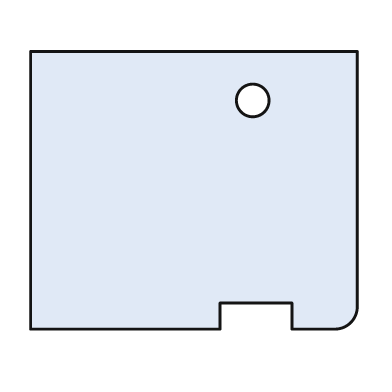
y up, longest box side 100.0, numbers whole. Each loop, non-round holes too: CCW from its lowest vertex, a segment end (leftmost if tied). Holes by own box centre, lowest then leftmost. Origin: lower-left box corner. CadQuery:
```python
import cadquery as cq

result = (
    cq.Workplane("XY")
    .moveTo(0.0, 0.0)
    .lineTo(58.0, 0.0)
    .lineTo(58.0, 8.0)
    .lineTo(80.0, 8.0)
    .lineTo(80.0, 0.0)
    .lineTo(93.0, 0.0)
    .threePointArc((98.0, 2.0), (100.0, 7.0))
    .lineTo(100.0, 85.0)
    .lineTo(0.0, 85.0)
    .close()
    .moveTo(68.0, 70.0)
    .circle(5.0)
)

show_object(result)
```